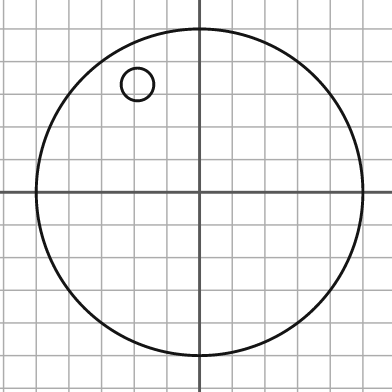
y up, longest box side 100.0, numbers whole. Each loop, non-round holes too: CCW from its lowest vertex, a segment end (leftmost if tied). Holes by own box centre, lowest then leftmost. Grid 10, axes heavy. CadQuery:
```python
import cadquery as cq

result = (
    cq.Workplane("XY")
    .moveTo(0.0, 0.0)
    .circle(50.0)
    .moveTo(-19.0, 33.0)
    .circle(5.0)
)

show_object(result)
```